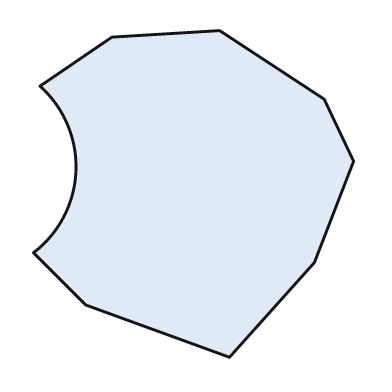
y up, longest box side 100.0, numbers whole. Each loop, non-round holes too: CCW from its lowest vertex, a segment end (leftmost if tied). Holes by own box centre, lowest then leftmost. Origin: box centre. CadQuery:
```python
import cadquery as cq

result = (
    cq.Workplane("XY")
    .moveTo(11.0, -50.0)
    .lineTo(37.0, -21.0)
    .lineTo(49.0, 10.0)
    .lineTo(40.0, 29.0)
    .lineTo(8.0, 50.0)
    .lineTo(-25.0, 48.0)
    .lineTo(-47.0, 33.0)
    .threePointArc((-36.0, 7.0), (-49.0, -18.0))
    .lineTo(-33.0, -34.0)
    .close()
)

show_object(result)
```